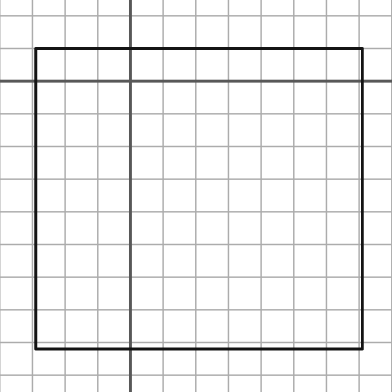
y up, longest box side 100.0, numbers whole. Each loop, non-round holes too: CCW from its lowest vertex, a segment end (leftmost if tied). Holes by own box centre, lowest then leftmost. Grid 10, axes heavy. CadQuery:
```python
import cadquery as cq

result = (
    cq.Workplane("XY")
    .moveTo(-29.0, -82.0)
    .lineTo(71.0, -82.0)
    .lineTo(71.0, 10.0)
    .lineTo(-29.0, 10.0)
    .close()
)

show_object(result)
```